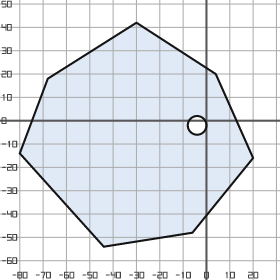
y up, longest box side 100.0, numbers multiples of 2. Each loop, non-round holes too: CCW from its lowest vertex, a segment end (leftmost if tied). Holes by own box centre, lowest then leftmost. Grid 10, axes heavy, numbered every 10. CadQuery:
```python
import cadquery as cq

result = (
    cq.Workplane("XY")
    .moveTo(-44.0, -54.0)
    .lineTo(-6.0, -48.0)
    .lineTo(20.0, -16.0)
    .lineTo(4.0, 20.0)
    .lineTo(-30.0, 42.0)
    .lineTo(-68.0, 18.0)
    .lineTo(-80.0, -14.0)
    .close()
    .moveTo(-4.0, -2.0)
    .circle(4.0)
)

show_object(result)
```